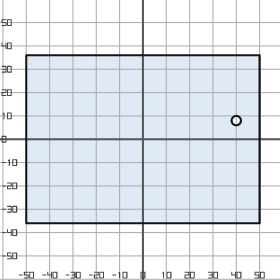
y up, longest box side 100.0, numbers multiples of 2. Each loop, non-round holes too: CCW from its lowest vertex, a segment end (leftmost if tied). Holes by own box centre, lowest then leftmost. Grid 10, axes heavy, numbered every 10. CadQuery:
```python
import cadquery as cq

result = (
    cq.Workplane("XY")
    .moveTo(-50.0, -36.0)
    .lineTo(50.0, -36.0)
    .lineTo(50.0, 36.0)
    .lineTo(-50.0, 36.0)
    .close()
    .moveTo(40.0, 8.0)
    .circle(2.0)
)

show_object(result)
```